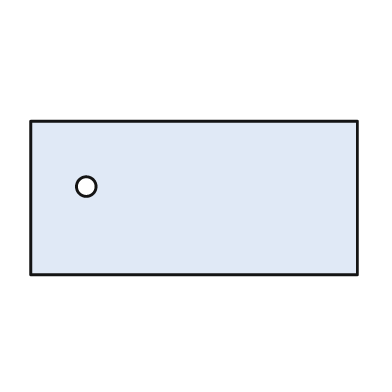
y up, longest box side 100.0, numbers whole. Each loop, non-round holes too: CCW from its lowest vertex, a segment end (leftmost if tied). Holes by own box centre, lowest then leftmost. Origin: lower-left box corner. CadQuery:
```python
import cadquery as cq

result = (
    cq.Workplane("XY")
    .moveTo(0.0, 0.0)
    .lineTo(100.0, 0.0)
    .lineTo(100.0, 47.0)
    .lineTo(0.0, 47.0)
    .close()
    .moveTo(17.0, 27.0)
    .circle(3.0)
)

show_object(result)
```